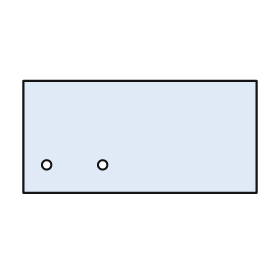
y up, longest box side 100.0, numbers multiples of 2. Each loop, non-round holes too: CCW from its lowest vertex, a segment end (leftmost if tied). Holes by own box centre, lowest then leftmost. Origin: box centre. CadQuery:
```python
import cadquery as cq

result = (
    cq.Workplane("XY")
    .moveTo(-50.0, -24.0)
    .lineTo(50.0, -24.0)
    .lineTo(50.0, 24.0)
    .lineTo(-50.0, 24.0)
    .close()
    .moveTo(-40.0, -12.0)
    .circle(2.0)
    .moveTo(-16.0, -12.0)
    .circle(2.0)
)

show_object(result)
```